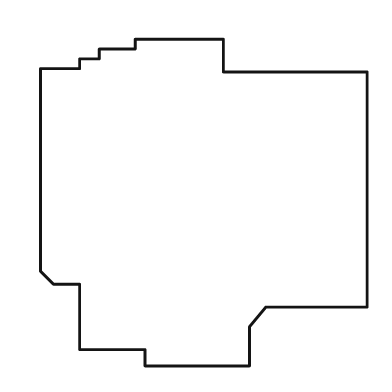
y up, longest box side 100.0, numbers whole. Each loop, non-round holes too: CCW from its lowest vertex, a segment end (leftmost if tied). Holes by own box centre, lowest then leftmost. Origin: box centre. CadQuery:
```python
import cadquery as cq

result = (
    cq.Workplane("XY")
    .moveTo(-18.0, -50.0)
    .lineTo(14.0, -50.0)
    .lineTo(14.0, -38.0)
    .lineTo(19.0, -32.0)
    .lineTo(50.0, -32.0)
    .lineTo(50.0, 40.0)
    .lineTo(6.0, 40.0)
    .lineTo(6.0, 50.0)
    .lineTo(-21.0, 50.0)
    .lineTo(-21.0, 47.0)
    .lineTo(-32.0, 47.0)
    .lineTo(-32.0, 44.0)
    .lineTo(-38.0, 44.0)
    .lineTo(-38.0, 41.0)
    .lineTo(-50.0, 41.0)
    .lineTo(-50.0, -21.0)
    .lineTo(-46.0, -25.0)
    .lineTo(-38.0, -25.0)
    .lineTo(-38.0, -45.0)
    .lineTo(-18.0, -45.0)
    .close()
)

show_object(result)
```